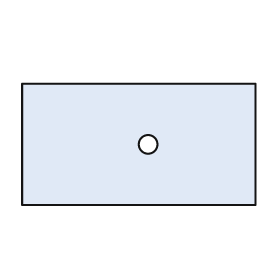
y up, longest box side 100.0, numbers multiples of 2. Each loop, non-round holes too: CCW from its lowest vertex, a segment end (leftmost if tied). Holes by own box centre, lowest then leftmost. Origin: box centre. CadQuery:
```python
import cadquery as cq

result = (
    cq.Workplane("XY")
    .moveTo(-50.0, -26.0)
    .lineTo(50.0, -26.0)
    .lineTo(50.0, 26.0)
    .lineTo(-50.0, 26.0)
    .close()
    .moveTo(4.0, 0.0)
    .circle(4.0)
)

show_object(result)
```